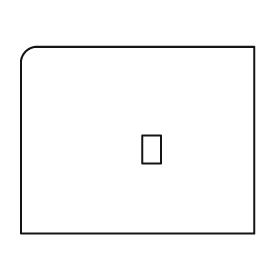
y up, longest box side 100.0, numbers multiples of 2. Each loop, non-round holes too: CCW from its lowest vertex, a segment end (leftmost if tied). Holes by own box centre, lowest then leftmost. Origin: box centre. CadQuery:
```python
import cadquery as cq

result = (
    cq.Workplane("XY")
    .moveTo(-50.0, -40.0)
    .lineTo(50.0, -40.0)
    .lineTo(50.0, 40.0)
    .lineTo(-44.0, 40.0)
    .threePointArc((-48.0, 38.0), (-50.0, 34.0))
    .close()
    .moveTo(2.0, -10.0)
    .lineTo(10.0, -10.0)
    .lineTo(10.0, 2.0)
    .lineTo(2.0, 2.0)
    .close()
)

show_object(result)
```